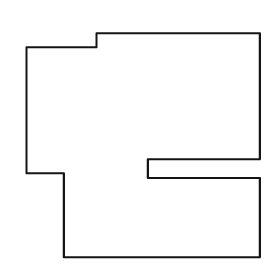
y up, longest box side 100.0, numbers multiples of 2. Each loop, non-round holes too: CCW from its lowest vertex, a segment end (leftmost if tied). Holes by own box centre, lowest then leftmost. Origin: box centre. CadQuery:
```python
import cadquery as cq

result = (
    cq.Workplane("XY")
    .moveTo(-34.0, -48.0)
    .lineTo(50.0, -48.0)
    .lineTo(50.0, -14.0)
    .lineTo(2.0, -14.0)
    .lineTo(2.0, -6.0)
    .lineTo(50.0, -6.0)
    .lineTo(50.0, 48.0)
    .lineTo(-20.0, 48.0)
    .lineTo(-20.0, 42.0)
    .lineTo(-50.0, 42.0)
    .lineTo(-50.0, -12.0)
    .lineTo(-34.0, -12.0)
    .close()
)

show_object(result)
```